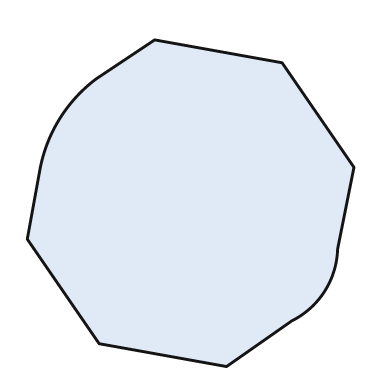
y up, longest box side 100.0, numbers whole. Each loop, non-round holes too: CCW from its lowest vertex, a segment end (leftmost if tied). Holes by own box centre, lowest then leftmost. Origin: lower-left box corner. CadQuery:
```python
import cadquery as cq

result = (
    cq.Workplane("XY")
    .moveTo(61.0, 0.0)
    .lineTo(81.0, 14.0)
    .threePointArc((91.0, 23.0), (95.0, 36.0))
    .lineTo(100.0, 61.0)
    .lineTo(78.0, 93.0)
    .lineTo(39.0, 100.0)
    .lineTo(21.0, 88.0)
    .threePointArc((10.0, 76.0), (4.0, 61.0))
    .lineTo(0.0, 39.0)
    .lineTo(22.0, 7.0)
    .close()
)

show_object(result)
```